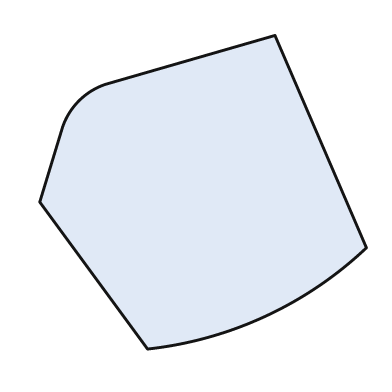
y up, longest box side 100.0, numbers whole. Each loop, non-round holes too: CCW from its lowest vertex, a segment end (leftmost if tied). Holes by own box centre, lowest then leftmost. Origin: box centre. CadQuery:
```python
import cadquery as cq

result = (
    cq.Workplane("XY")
    .moveTo(-17.0, -48.0)
    .threePointArc((19.0, -38.0), (50.0, -17.0))
    .lineTo(22.0, 48.0)
    .lineTo(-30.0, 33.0)
    .threePointArc((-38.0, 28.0), (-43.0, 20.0))
    .lineTo(-50.0, -3.0)
    .close()
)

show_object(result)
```